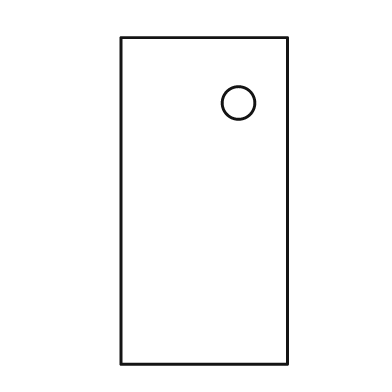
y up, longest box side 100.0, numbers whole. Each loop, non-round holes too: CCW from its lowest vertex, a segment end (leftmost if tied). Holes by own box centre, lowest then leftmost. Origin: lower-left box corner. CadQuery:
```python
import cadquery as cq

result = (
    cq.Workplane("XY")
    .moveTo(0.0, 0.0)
    .lineTo(51.0, 0.0)
    .lineTo(51.0, 100.0)
    .lineTo(0.0, 100.0)
    .close()
    .moveTo(36.0, 80.0)
    .circle(5.0)
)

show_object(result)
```